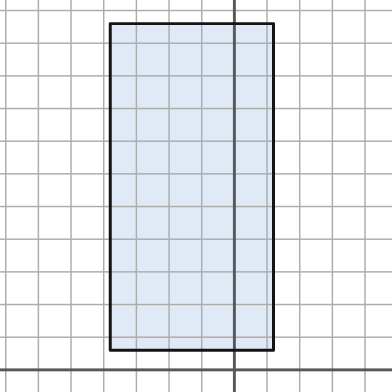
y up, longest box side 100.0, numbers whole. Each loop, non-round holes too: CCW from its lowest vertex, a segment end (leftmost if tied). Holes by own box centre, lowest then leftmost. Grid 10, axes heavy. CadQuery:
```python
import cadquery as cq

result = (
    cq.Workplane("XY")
    .moveTo(-38.0, 6.0)
    .lineTo(12.0, 6.0)
    .lineTo(12.0, 106.0)
    .lineTo(-38.0, 106.0)
    .close()
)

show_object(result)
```